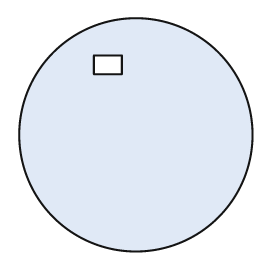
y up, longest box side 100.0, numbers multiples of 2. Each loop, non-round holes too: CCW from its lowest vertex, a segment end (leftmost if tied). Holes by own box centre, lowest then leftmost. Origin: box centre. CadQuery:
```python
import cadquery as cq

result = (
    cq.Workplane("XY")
    .moveTo(0.0, 0.0)
    .circle(50.0)
    .moveTo(-18.0, 26.0)
    .lineTo(-6.0, 26.0)
    .lineTo(-6.0, 34.0)
    .lineTo(-18.0, 34.0)
    .close()
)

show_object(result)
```